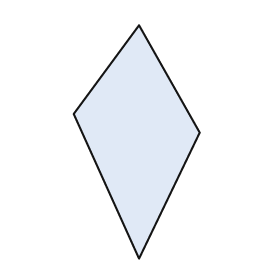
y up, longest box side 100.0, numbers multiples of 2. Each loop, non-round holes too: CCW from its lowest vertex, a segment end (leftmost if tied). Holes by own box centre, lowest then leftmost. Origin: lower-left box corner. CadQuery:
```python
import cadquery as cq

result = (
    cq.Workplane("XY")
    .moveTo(28.0, 0.0)
    .lineTo(54.0, 54.0)
    .lineTo(28.0, 100.0)
    .lineTo(0.0, 62.0)
    .close()
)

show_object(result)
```